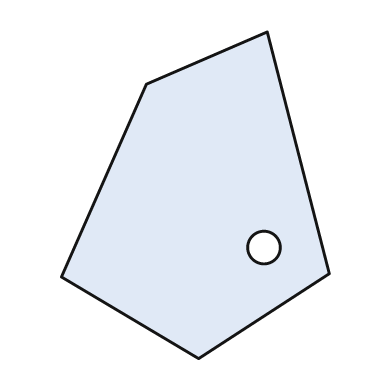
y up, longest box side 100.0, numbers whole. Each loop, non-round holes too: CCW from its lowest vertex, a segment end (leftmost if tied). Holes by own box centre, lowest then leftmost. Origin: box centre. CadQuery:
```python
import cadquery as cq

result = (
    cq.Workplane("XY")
    .moveTo(1.0, -50.0)
    .lineTo(41.0, -24.0)
    .lineTo(22.0, 50.0)
    .lineTo(-15.0, 34.0)
    .lineTo(-41.0, -25.0)
    .close()
    .moveTo(21.0, -16.0)
    .circle(5.0)
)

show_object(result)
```